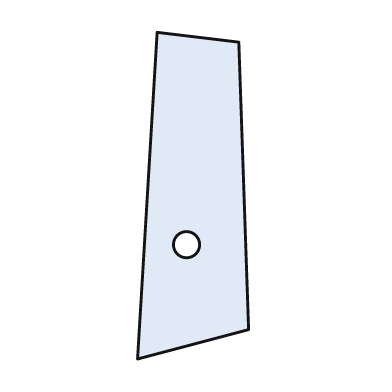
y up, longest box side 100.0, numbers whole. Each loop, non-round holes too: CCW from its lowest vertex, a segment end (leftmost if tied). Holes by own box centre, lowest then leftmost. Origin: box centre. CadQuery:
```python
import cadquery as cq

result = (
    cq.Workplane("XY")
    .moveTo(-17.0, -50.0)
    .lineTo(17.0, -41.0)
    .lineTo(14.0, 47.0)
    .lineTo(-11.0, 50.0)
    .close()
    .moveTo(-2.0, -15.0)
    .circle(4.0)
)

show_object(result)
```